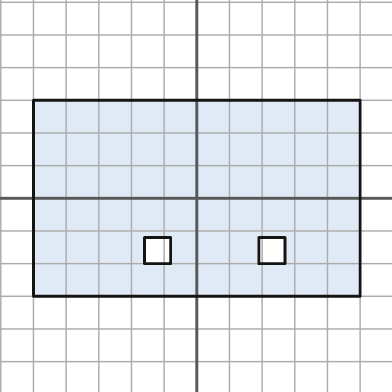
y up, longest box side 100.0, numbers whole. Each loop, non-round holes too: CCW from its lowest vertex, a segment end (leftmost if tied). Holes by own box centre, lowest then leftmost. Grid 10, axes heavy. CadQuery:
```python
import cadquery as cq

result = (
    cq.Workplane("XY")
    .moveTo(-50.0, -30.0)
    .lineTo(50.0, -30.0)
    .lineTo(50.0, 30.0)
    .lineTo(-50.0, 30.0)
    .close()
    .moveTo(-16.0, -20.0)
    .lineTo(-8.0, -20.0)
    .lineTo(-8.0, -12.0)
    .lineTo(-16.0, -12.0)
    .close()
    .moveTo(19.0, -20.0)
    .lineTo(27.0, -20.0)
    .lineTo(27.0, -12.0)
    .lineTo(19.0, -12.0)
    .close()
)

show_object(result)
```